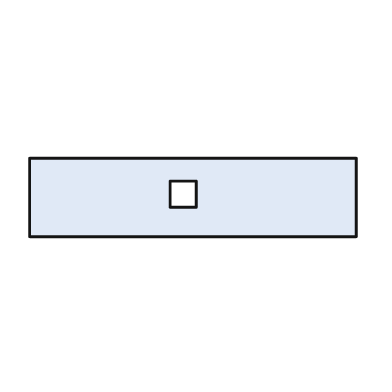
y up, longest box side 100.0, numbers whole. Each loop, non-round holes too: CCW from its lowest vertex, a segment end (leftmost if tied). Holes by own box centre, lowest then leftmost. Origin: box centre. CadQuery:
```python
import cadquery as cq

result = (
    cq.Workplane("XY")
    .moveTo(-50.0, -12.0)
    .lineTo(50.0, -12.0)
    .lineTo(50.0, 12.0)
    .lineTo(-50.0, 12.0)
    .close()
    .moveTo(-7.0, -3.0)
    .lineTo(1.0, -3.0)
    .lineTo(1.0, 5.0)
    .lineTo(-7.0, 5.0)
    .close()
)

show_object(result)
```